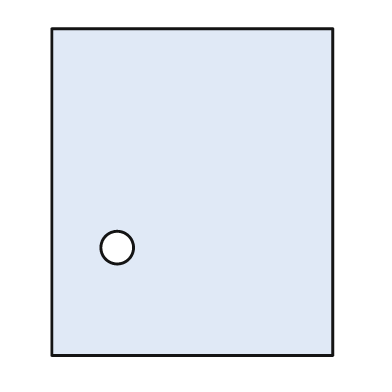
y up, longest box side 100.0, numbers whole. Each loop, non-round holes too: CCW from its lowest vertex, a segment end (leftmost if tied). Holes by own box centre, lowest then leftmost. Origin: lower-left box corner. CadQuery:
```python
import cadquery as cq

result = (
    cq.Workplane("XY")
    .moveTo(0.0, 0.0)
    .lineTo(86.0, 0.0)
    .lineTo(86.0, 100.0)
    .lineTo(0.0, 100.0)
    .close()
    .moveTo(20.0, 33.0)
    .circle(5.0)
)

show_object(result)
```